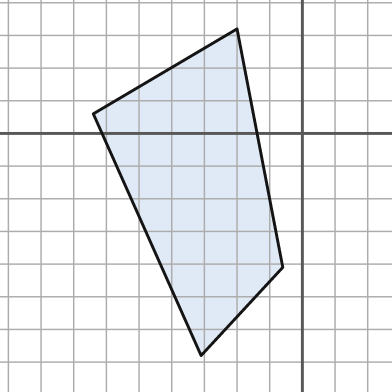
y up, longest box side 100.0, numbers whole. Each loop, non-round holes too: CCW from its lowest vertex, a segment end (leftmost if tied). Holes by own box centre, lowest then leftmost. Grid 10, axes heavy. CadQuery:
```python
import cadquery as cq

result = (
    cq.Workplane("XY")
    .moveTo(-31.0, -68.0)
    .lineTo(-6.0, -41.0)
    .lineTo(-20.0, 32.0)
    .lineTo(-64.0, 6.0)
    .close()
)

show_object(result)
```